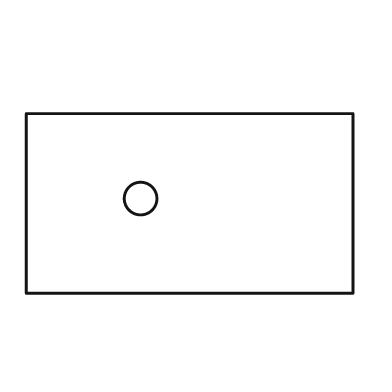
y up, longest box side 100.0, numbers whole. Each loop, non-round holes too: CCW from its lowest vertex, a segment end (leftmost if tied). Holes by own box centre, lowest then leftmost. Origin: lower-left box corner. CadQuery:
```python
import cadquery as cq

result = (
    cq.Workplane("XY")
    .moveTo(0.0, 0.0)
    .lineTo(100.0, 0.0)
    .lineTo(100.0, 55.0)
    .lineTo(0.0, 55.0)
    .close()
    .moveTo(35.0, 29.0)
    .circle(5.0)
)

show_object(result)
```